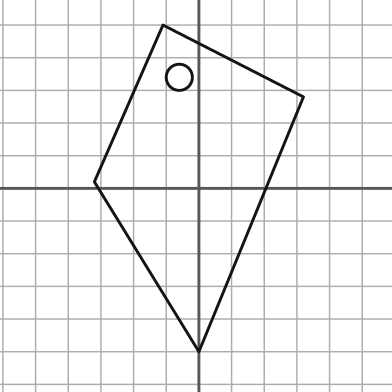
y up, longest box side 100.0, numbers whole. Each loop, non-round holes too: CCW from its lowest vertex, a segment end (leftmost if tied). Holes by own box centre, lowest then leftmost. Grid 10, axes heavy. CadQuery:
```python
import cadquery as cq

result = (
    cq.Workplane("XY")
    .moveTo(0.0, -50.0)
    .lineTo(32.0, 28.0)
    .lineTo(-11.0, 50.0)
    .lineTo(-32.0, 2.0)
    .close()
    .moveTo(-6.0, 34.0)
    .circle(4.0)
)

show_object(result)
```